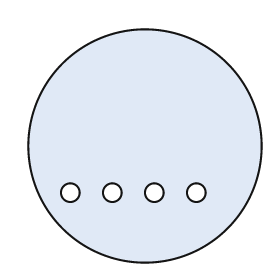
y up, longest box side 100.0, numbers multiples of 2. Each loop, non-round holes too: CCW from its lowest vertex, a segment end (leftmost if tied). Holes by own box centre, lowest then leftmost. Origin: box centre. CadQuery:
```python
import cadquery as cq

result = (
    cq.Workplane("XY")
    .moveTo(0.0, 0.0)
    .circle(50.0)
    .moveTo(-32.0, -20.0)
    .circle(4.0)
    .moveTo(-14.0, -20.0)
    .circle(4.0)
    .moveTo(4.0, -20.0)
    .circle(4.0)
    .moveTo(22.0, -20.0)
    .circle(4.0)
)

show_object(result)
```